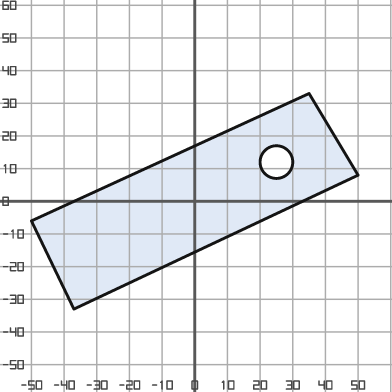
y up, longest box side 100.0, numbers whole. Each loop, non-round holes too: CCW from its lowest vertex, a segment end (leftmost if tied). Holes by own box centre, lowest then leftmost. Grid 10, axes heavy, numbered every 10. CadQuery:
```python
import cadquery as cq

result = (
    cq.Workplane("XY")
    .moveTo(-37.0, -33.0)
    .lineTo(50.0, 8.0)
    .lineTo(35.0, 33.0)
    .lineTo(-50.0, -6.0)
    .close()
    .moveTo(25.0, 12.0)
    .circle(5.0)
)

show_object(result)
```